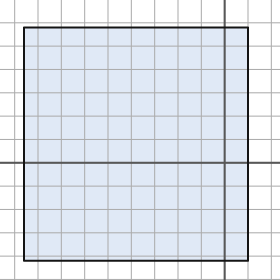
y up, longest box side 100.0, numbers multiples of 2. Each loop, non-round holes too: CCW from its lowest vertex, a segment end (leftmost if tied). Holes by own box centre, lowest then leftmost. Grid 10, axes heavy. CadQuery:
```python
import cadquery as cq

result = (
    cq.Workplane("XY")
    .moveTo(-86.0, -42.0)
    .lineTo(10.0, -42.0)
    .lineTo(10.0, 58.0)
    .lineTo(-86.0, 58.0)
    .close()
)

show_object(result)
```